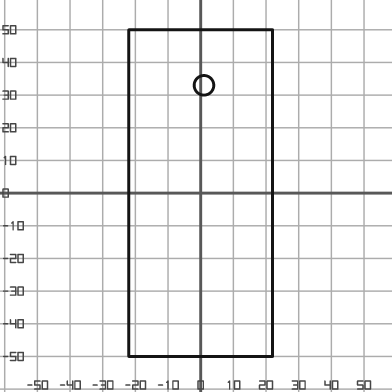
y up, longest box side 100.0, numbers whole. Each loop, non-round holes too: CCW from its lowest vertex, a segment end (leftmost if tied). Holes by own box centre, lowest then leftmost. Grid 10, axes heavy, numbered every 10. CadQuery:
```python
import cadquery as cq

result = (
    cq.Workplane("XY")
    .moveTo(-22.0, -50.0)
    .lineTo(22.0, -50.0)
    .lineTo(22.0, 50.0)
    .lineTo(-22.0, 50.0)
    .close()
    .moveTo(1.0, 33.0)
    .circle(3.0)
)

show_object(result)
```